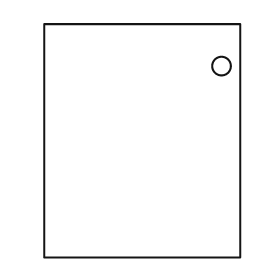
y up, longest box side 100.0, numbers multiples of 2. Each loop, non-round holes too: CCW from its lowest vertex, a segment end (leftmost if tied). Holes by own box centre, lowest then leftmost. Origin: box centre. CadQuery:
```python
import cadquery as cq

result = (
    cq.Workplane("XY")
    .moveTo(-42.0, -50.0)
    .lineTo(42.0, -50.0)
    .lineTo(42.0, 50.0)
    .lineTo(-42.0, 50.0)
    .close()
    .moveTo(34.0, 32.0)
    .circle(4.0)
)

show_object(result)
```